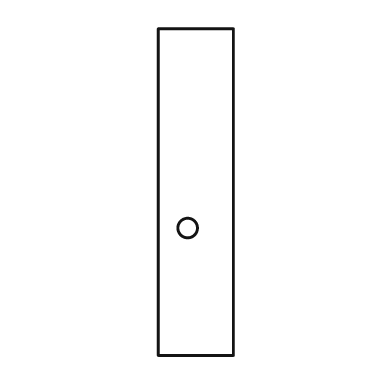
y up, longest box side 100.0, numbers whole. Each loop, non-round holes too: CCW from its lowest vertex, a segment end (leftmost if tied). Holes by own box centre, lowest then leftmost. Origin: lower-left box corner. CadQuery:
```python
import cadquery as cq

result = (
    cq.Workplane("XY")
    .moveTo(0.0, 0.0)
    .lineTo(23.0, 0.0)
    .lineTo(23.0, 100.0)
    .lineTo(0.0, 100.0)
    .close()
    .moveTo(9.0, 39.0)
    .circle(3.0)
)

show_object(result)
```